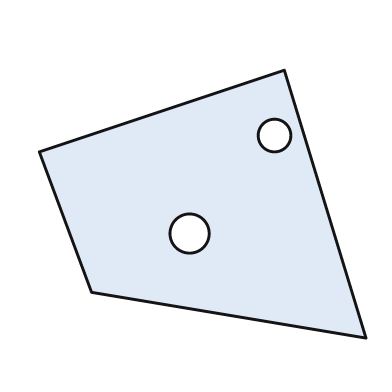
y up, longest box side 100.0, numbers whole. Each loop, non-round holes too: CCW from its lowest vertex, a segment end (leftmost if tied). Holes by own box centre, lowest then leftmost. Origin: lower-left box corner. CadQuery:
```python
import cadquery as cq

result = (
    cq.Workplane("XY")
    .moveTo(100.0, 0.0)
    .lineTo(75.0, 82.0)
    .lineTo(0.0, 57.0)
    .lineTo(16.0, 14.0)
    .close()
    .moveTo(46.0, 32.0)
    .circle(6.0)
    .moveTo(72.0, 62.0)
    .circle(5.0)
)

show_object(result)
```